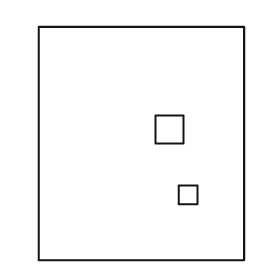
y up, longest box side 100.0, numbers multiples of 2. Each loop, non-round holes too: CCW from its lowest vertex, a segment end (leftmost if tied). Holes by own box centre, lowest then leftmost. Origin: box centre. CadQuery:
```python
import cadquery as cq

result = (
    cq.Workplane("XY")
    .moveTo(-44.0, -50.0)
    .lineTo(44.0, -50.0)
    .lineTo(44.0, 50.0)
    .lineTo(-44.0, 50.0)
    .close()
    .moveTo(16.0, -26.0)
    .lineTo(24.0, -26.0)
    .lineTo(24.0, -18.0)
    .lineTo(16.0, -18.0)
    .close()
    .moveTo(6.0, 0.0)
    .lineTo(18.0, 0.0)
    .lineTo(18.0, 12.0)
    .lineTo(6.0, 12.0)
    .close()
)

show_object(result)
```